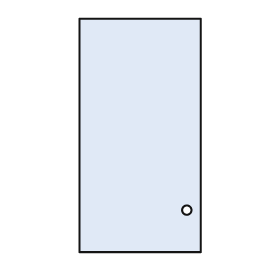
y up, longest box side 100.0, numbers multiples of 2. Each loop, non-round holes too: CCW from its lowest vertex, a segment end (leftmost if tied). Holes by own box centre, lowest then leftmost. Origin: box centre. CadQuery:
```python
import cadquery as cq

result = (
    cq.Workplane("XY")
    .moveTo(-26.0, -50.0)
    .lineTo(26.0, -50.0)
    .lineTo(26.0, 50.0)
    .lineTo(-26.0, 50.0)
    .close()
    .moveTo(20.0, -32.0)
    .circle(2.0)
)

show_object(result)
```